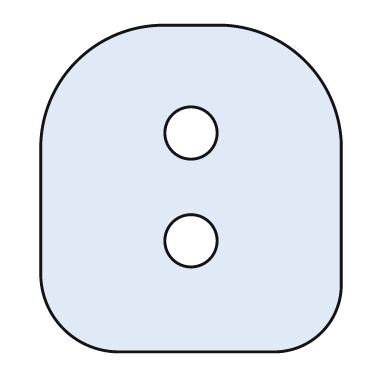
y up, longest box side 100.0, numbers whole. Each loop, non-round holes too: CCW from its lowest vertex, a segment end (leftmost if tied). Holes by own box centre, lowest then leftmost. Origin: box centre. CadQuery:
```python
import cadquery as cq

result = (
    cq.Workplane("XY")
    .moveTo(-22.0, -50.0)
    .lineTo(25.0, -50.0)
    .threePointArc((40.0, -44.0), (46.0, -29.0))
    .lineTo(46.0, 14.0)
    .threePointArc((35.0, 39.0), (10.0, 50.0))
    .lineTo(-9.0, 50.0)
    .threePointArc((-35.0, 39.0), (-46.0, 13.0))
    .lineTo(-46.0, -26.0)
    .threePointArc((-39.0, -43.0), (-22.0, -50.0))
    .close()
    .moveTo(0.0, -16.0)
    .circle(8.0)
    .moveTo(0.0, 17.0)
    .circle(8.0)
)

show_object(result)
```